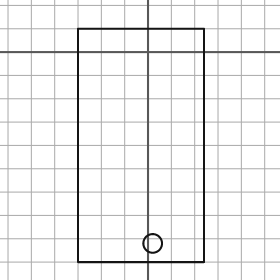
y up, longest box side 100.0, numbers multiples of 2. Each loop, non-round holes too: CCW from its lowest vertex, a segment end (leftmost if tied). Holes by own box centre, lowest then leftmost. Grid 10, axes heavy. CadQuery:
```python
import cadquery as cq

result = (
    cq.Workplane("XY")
    .moveTo(-30.0, -90.0)
    .lineTo(24.0, -90.0)
    .lineTo(24.0, 10.0)
    .lineTo(-30.0, 10.0)
    .close()
    .moveTo(2.0, -82.0)
    .circle(4.0)
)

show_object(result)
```